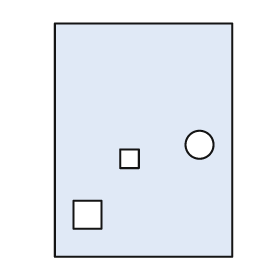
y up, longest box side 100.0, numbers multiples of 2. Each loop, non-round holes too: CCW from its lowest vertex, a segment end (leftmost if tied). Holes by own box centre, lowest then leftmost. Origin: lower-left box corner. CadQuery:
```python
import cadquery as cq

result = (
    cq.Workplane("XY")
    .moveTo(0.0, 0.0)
    .lineTo(76.0, 0.0)
    .lineTo(76.0, 100.0)
    .lineTo(0.0, 100.0)
    .close()
    .moveTo(8.0, 12.0)
    .lineTo(20.0, 12.0)
    .lineTo(20.0, 24.0)
    .lineTo(8.0, 24.0)
    .close()
    .moveTo(28.0, 38.0)
    .lineTo(36.0, 38.0)
    .lineTo(36.0, 46.0)
    .lineTo(28.0, 46.0)
    .close()
    .moveTo(62.0, 48.0)
    .circle(6.0)
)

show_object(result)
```